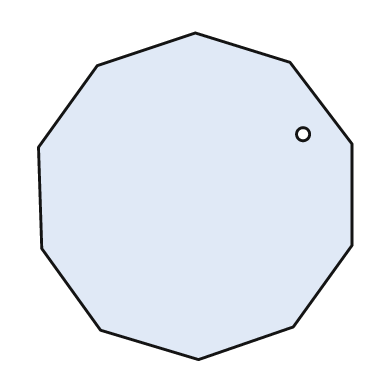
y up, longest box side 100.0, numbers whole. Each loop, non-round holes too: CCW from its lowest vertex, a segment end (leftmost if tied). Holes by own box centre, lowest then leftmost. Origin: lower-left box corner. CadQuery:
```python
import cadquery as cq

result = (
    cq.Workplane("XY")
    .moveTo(49.0, 0.0)
    .lineTo(78.0, 10.0)
    .lineTo(96.0, 35.0)
    .lineTo(96.0, 66.0)
    .lineTo(77.0, 91.0)
    .lineTo(48.0, 100.0)
    .lineTo(18.0, 90.0)
    .lineTo(0.0, 65.0)
    .lineTo(1.0, 34.0)
    .lineTo(19.0, 9.0)
    .close()
    .moveTo(81.0, 69.0)
    .circle(2.0)
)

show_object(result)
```